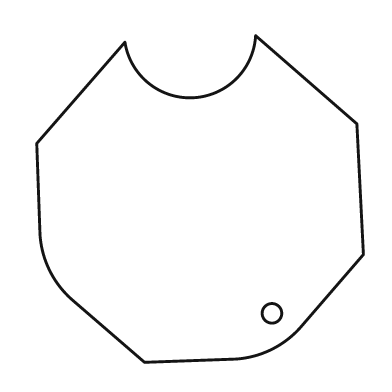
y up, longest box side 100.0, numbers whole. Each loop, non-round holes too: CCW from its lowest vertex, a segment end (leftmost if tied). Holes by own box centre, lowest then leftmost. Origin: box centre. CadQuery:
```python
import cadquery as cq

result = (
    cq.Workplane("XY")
    .moveTo(-17.0, -50.0)
    .lineTo(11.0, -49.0)
    .threePointArc((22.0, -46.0), (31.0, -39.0))
    .lineTo(50.0, -17.0)
    .lineTo(48.0, 23.0)
    .lineTo(17.0, 50.0)
    .threePointArc((-2.0, 31.0), (-23.0, 48.0))
    .lineTo(-50.0, 17.0)
    .lineTo(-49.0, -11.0)
    .threePointArc((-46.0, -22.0), (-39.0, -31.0))
    .close()
    .moveTo(22.0, -35.0)
    .circle(3.0)
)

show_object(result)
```